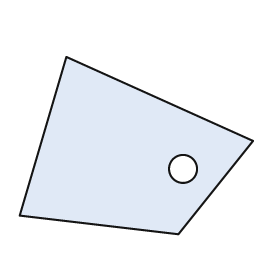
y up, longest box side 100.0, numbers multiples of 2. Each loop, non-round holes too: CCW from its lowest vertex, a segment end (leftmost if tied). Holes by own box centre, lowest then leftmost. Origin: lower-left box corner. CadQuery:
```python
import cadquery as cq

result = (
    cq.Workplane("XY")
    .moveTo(68.0, 0.0)
    .lineTo(100.0, 40.0)
    .lineTo(20.0, 76.0)
    .lineTo(0.0, 8.0)
    .close()
    .moveTo(70.0, 28.0)
    .circle(6.0)
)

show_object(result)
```